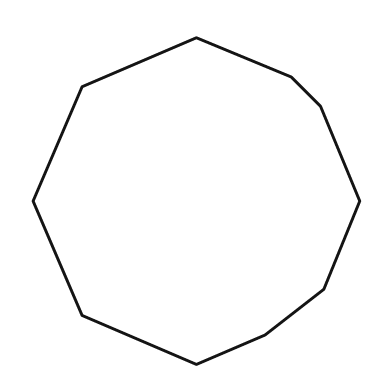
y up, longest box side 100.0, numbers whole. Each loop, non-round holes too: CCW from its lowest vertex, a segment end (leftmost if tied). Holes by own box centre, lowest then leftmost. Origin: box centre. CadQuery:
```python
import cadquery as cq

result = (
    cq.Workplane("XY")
    .moveTo(0.0, -50.0)
    .lineTo(21.0, -41.0)
    .lineTo(39.0, -27.0)
    .lineTo(50.0, 0.0)
    .lineTo(38.0, 29.0)
    .lineTo(29.0, 38.0)
    .lineTo(0.0, 50.0)
    .lineTo(-35.0, 35.0)
    .lineTo(-50.0, 0.0)
    .lineTo(-35.0, -35.0)
    .close()
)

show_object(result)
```